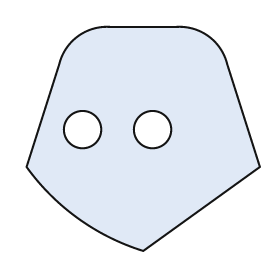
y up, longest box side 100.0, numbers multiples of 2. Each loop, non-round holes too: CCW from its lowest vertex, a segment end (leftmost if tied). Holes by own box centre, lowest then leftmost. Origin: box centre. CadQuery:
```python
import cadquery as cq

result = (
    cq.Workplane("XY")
    .moveTo(0.0, -48.0)
    .lineTo(50.0, -12.0)
    .lineTo(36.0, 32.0)
    .threePointArc((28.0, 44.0), (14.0, 48.0))
    .lineTo(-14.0, 48.0)
    .threePointArc((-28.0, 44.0), (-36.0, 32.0))
    .lineTo(-50.0, -12.0)
    .threePointArc((-28.0, -34.0), (0.0, -48.0))
    .close()
    .moveTo(-26.0, 4.0)
    .circle(8.0)
    .moveTo(4.0, 4.0)
    .circle(8.0)
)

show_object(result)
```